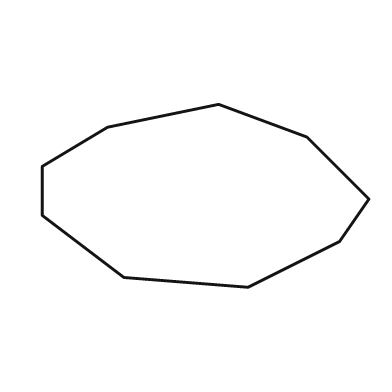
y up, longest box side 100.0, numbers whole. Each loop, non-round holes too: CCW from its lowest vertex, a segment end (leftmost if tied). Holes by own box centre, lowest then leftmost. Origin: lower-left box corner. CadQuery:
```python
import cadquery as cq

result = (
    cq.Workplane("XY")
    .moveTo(63.0, 0.0)
    .lineTo(91.0, 14.0)
    .lineTo(100.0, 27.0)
    .lineTo(81.0, 46.0)
    .lineTo(54.0, 56.0)
    .lineTo(20.0, 49.0)
    .lineTo(0.0, 37.0)
    .lineTo(0.0, 22.0)
    .lineTo(25.0, 3.0)
    .close()
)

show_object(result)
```